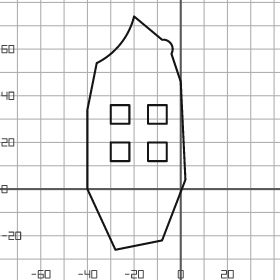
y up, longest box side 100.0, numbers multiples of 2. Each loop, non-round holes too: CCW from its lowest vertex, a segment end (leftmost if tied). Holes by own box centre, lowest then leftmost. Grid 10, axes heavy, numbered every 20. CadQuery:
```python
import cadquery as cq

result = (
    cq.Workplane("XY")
    .moveTo(-28.0, -26.0)
    .lineTo(-8.0, -22.0)
    .lineTo(2.0, 4.0)
    .lineTo(0.0, 46.0)
    .lineTo(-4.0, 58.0)
    .threePointArc((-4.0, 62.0), (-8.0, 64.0))
    .lineTo(-20.0, 74.0)
    .threePointArc((-26.0, 62.0), (-36.0, 54.0))
    .lineTo(-40.0, 34.0)
    .lineTo(-40.0, 0.0)
    .close()
    .moveTo(-30.0, 12.0)
    .lineTo(-22.0, 12.0)
    .lineTo(-22.0, 20.0)
    .lineTo(-30.0, 20.0)
    .close()
    .moveTo(-14.0, 12.0)
    .lineTo(-6.0, 12.0)
    .lineTo(-6.0, 20.0)
    .lineTo(-14.0, 20.0)
    .close()
    .moveTo(-30.0, 28.0)
    .lineTo(-22.0, 28.0)
    .lineTo(-22.0, 36.0)
    .lineTo(-30.0, 36.0)
    .close()
    .moveTo(-14.0, 28.0)
    .lineTo(-6.0, 28.0)
    .lineTo(-6.0, 36.0)
    .lineTo(-14.0, 36.0)
    .close()
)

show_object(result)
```